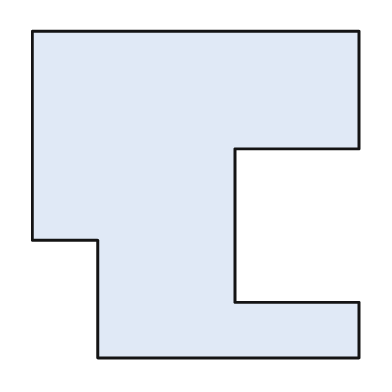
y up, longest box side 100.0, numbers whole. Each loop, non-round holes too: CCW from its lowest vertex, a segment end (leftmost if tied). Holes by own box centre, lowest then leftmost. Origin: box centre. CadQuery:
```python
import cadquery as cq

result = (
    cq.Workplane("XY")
    .moveTo(-30.0, -50.0)
    .lineTo(50.0, -50.0)
    .lineTo(50.0, -33.0)
    .lineTo(12.0, -33.0)
    .lineTo(12.0, 14.0)
    .lineTo(50.0, 14.0)
    .lineTo(50.0, 50.0)
    .lineTo(-50.0, 50.0)
    .lineTo(-50.0, -14.0)
    .lineTo(-30.0, -14.0)
    .close()
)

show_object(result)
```